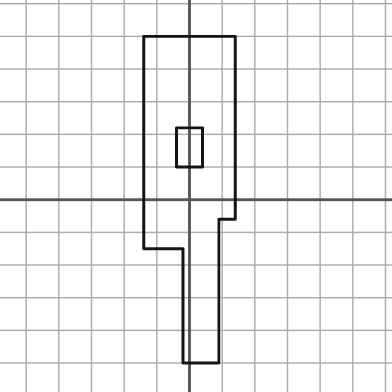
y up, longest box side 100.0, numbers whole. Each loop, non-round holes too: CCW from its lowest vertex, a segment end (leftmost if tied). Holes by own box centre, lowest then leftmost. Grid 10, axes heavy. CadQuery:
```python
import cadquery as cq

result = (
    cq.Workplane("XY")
    .moveTo(-2.0, -50.0)
    .lineTo(9.0, -50.0)
    .lineTo(9.0, -6.0)
    .lineTo(14.0, -6.0)
    .lineTo(14.0, 50.0)
    .lineTo(-14.0, 50.0)
    .lineTo(-14.0, -15.0)
    .lineTo(-2.0, -15.0)
    .close()
    .moveTo(-4.0, 10.0)
    .lineTo(4.0, 10.0)
    .lineTo(4.0, 22.0)
    .lineTo(-4.0, 22.0)
    .close()
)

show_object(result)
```